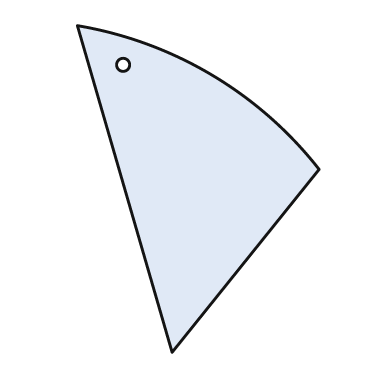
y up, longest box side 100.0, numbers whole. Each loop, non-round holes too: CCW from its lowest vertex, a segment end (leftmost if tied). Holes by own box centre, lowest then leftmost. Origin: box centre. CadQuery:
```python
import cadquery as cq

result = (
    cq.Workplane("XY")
    .moveTo(-8.0, -50.0)
    .lineTo(37.0, 6.0)
    .threePointArc((4.0, 35.0), (-37.0, 50.0))
    .close()
    .moveTo(-23.0, 38.0)
    .circle(2.0)
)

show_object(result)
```